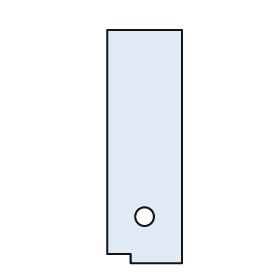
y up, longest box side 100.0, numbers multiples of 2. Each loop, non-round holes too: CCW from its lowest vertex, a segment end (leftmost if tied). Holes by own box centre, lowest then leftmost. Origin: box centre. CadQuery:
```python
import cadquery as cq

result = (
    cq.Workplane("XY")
    .moveTo(-6.0, -50.0)
    .lineTo(16.0, -50.0)
    .lineTo(16.0, 50.0)
    .lineTo(-16.0, 50.0)
    .lineTo(-16.0, -46.0)
    .lineTo(-6.0, -46.0)
    .close()
    .moveTo(0.0, -30.0)
    .circle(4.0)
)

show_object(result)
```